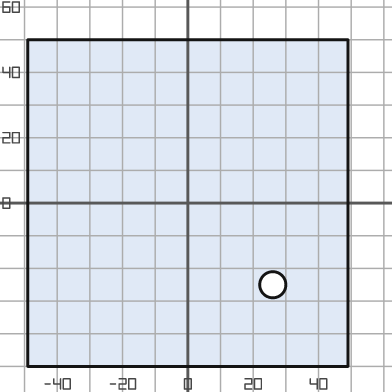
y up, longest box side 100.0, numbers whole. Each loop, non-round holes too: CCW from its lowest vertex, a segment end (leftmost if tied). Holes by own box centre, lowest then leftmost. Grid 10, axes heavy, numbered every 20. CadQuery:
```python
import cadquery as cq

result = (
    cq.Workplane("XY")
    .moveTo(-49.0, -50.0)
    .lineTo(49.0, -50.0)
    .lineTo(49.0, 50.0)
    .lineTo(-49.0, 50.0)
    .close()
    .moveTo(26.0, -25.0)
    .circle(4.0)
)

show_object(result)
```